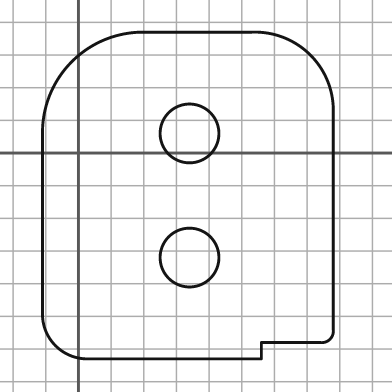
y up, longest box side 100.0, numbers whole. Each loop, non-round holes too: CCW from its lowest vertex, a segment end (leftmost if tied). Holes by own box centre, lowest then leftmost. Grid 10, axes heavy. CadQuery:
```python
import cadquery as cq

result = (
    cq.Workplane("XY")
    .moveTo(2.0, -63.0)
    .lineTo(56.0, -63.0)
    .lineTo(56.0, -58.0)
    .lineTo(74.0, -58.0)
    .threePointArc((77.0, -57.0), (78.0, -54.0))
    .lineTo(78.0, 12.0)
    .threePointArc((71.0, 30.0), (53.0, 37.0))
    .lineTo(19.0, 37.0)
    .threePointArc((-2.0, 28.0), (-11.0, 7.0))
    .lineTo(-11.0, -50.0)
    .threePointArc((-7.0, -59.0), (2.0, -63.0))
    .close()
    .moveTo(34.0, -32.0)
    .circle(9.0)
    .moveTo(34.0, 6.0)
    .circle(9.0)
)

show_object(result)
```